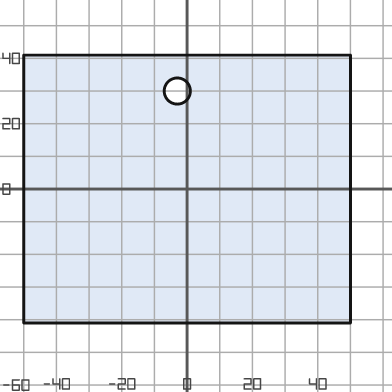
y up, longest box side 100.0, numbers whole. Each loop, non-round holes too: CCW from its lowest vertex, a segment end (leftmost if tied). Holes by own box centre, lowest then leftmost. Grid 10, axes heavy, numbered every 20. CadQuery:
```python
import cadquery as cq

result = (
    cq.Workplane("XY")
    .moveTo(-50.0, -41.0)
    .lineTo(50.0, -41.0)
    .lineTo(50.0, 41.0)
    .lineTo(-50.0, 41.0)
    .close()
    .moveTo(-3.0, 30.0)
    .circle(4.0)
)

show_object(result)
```